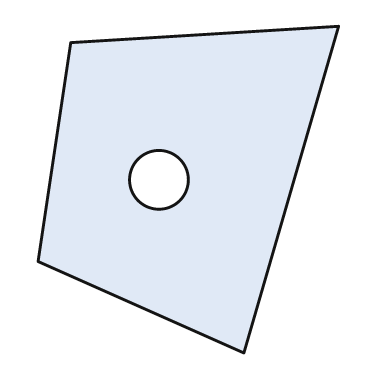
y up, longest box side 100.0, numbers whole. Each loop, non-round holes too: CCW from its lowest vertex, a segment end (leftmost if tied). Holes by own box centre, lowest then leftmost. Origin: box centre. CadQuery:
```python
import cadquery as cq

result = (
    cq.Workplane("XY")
    .moveTo(17.0, -50.0)
    .lineTo(46.0, 50.0)
    .lineTo(-36.0, 45.0)
    .lineTo(-46.0, -22.0)
    .close()
    .moveTo(-9.0, 3.0)
    .circle(9.0)
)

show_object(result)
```